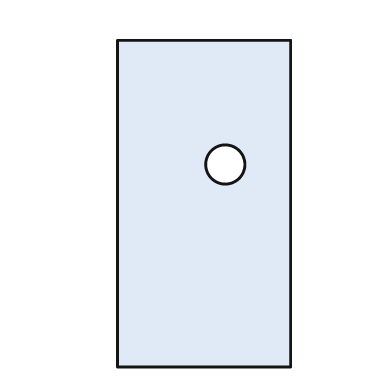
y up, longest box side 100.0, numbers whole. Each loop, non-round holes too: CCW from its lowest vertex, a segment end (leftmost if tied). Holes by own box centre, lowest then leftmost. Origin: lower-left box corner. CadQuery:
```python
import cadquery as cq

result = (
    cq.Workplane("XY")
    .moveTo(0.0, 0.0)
    .lineTo(53.0, 0.0)
    .lineTo(53.0, 100.0)
    .lineTo(0.0, 100.0)
    .close()
    .moveTo(33.0, 62.0)
    .circle(6.0)
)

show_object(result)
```